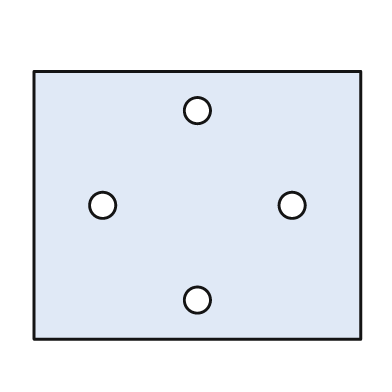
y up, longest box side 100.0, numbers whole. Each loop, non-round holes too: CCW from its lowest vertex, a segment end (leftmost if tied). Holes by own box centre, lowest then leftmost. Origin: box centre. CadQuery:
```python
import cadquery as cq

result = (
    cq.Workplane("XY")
    .moveTo(-50.0, -41.0)
    .lineTo(50.0, -41.0)
    .lineTo(50.0, 41.0)
    .lineTo(-50.0, 41.0)
    .close()
    .moveTo(0.0, -29.0)
    .circle(4.0)
    .moveTo(-29.0, 0.0)
    .circle(4.0)
    .moveTo(29.0, 0.0)
    .circle(4.0)
    .moveTo(0.0, 29.0)
    .circle(4.0)
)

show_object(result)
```